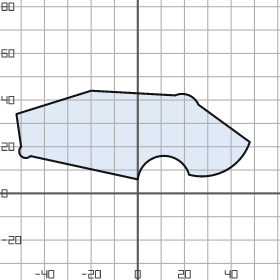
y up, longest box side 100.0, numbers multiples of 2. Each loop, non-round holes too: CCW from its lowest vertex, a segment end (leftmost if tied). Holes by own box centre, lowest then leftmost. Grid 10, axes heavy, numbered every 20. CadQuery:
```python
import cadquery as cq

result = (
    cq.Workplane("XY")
    .moveTo(0.0, 6.0)
    .threePointArc((10.0, 16.0), (22.0, 8.0))
    .threePointArc((38.0, 10.0), (48.0, 22.0))
    .lineTo(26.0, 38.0)
    .threePointArc((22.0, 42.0), (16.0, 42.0))
    .lineTo(-20.0, 44.0)
    .lineTo(-52.0, 34.0)
    .lineTo(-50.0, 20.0)
    .threePointArc((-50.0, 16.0), (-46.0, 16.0))
    .close()
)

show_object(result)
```